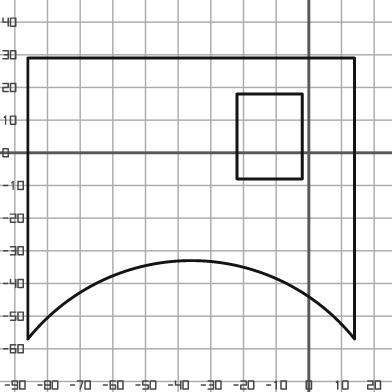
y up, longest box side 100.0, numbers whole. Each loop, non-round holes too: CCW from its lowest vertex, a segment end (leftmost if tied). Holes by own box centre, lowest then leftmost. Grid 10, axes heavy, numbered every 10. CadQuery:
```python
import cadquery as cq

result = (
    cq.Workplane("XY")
    .moveTo(-86.0, -57.0)
    .threePointArc((-36.0, -33.0), (14.0, -57.0))
    .lineTo(14.0, 29.0)
    .lineTo(-86.0, 29.0)
    .close()
    .moveTo(-22.0, -8.0)
    .lineTo(-2.0, -8.0)
    .lineTo(-2.0, 18.0)
    .lineTo(-22.0, 18.0)
    .close()
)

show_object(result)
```